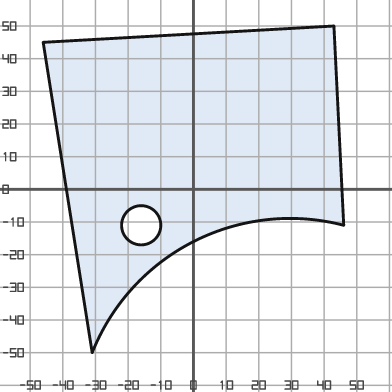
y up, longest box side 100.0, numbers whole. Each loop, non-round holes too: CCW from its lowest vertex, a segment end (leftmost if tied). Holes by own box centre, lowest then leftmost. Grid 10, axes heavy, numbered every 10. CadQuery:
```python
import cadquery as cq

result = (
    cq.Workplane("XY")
    .moveTo(-31.0, -50.0)
    .threePointArc((0.0, -16.0), (46.0, -11.0))
    .lineTo(43.0, 50.0)
    .lineTo(-46.0, 45.0)
    .close()
    .moveTo(-16.0, -11.0)
    .circle(6.0)
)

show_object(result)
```